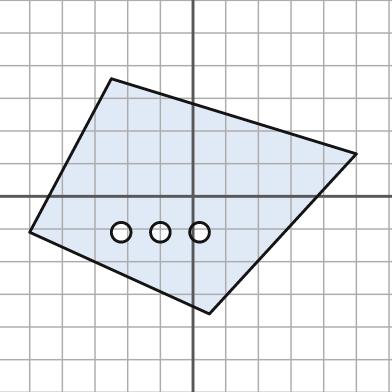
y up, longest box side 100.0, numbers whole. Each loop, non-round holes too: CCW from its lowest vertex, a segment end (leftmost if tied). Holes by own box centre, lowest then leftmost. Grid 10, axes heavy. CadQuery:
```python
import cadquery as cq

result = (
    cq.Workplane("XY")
    .moveTo(5.0, -36.0)
    .lineTo(50.0, 13.0)
    .lineTo(-25.0, 36.0)
    .lineTo(-50.0, -11.0)
    .close()
    .moveTo(-22.0, -11.0)
    .circle(3.0)
    .moveTo(-10.0, -11.0)
    .circle(3.0)
    .moveTo(2.0, -11.0)
    .circle(3.0)
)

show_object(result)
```